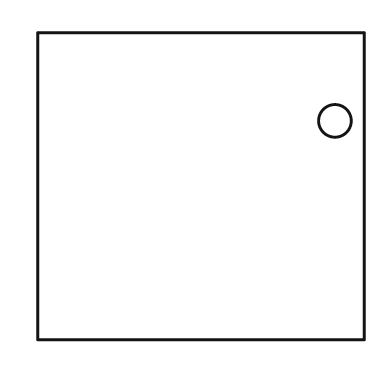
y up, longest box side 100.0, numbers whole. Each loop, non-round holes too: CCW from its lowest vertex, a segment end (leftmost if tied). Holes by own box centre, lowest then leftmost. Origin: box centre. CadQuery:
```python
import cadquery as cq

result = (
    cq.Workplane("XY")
    .moveTo(-50.0, -47.0)
    .lineTo(50.0, -47.0)
    .lineTo(50.0, 47.0)
    .lineTo(-50.0, 47.0)
    .close()
    .moveTo(41.0, 20.0)
    .circle(5.0)
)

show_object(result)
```